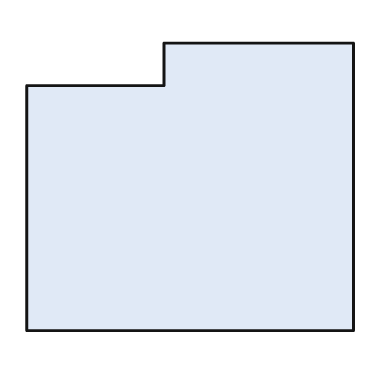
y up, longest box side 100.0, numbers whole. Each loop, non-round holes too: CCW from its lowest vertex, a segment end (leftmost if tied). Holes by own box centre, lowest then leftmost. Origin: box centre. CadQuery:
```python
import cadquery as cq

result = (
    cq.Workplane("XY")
    .moveTo(-50.0, -44.0)
    .lineTo(50.0, -44.0)
    .lineTo(50.0, 44.0)
    .lineTo(-8.0, 44.0)
    .lineTo(-8.0, 31.0)
    .lineTo(-50.0, 31.0)
    .close()
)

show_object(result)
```